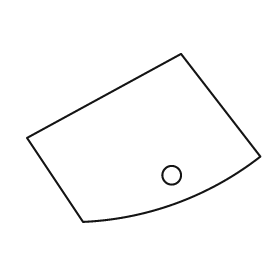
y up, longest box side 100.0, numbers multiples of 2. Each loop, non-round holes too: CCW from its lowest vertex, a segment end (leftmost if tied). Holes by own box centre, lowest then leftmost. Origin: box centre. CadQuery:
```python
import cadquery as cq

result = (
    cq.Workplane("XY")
    .moveTo(-26.0, -36.0)
    .threePointArc((14.0, -28.0), (50.0, -8.0))
    .lineTo(16.0, 36.0)
    .lineTo(-50.0, 0.0)
    .close()
    .moveTo(12.0, -16.0)
    .circle(4.0)
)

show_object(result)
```